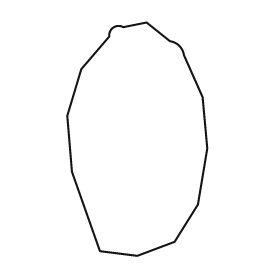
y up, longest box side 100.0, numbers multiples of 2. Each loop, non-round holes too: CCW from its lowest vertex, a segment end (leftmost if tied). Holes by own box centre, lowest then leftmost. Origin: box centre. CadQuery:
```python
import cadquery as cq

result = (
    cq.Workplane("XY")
    .moveTo(0.0, -50.0)
    .lineTo(16.0, -44.0)
    .lineTo(26.0, -28.0)
    .lineTo(30.0, -4.0)
    .lineTo(28.0, 18.0)
    .lineTo(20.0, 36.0)
    .threePointArc((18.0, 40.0), (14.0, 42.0))
    .lineTo(4.0, 50.0)
    .lineTo(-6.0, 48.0)
    .threePointArc((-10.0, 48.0), (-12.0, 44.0))
    .lineTo(-24.0, 30.0)
    .lineTo(-30.0, 10.0)
    .lineTo(-28.0, -14.0)
    .lineTo(-16.0, -48.0)
    .close()
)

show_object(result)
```